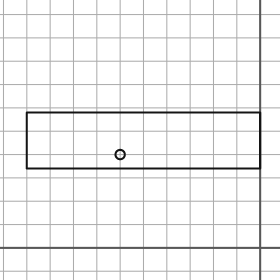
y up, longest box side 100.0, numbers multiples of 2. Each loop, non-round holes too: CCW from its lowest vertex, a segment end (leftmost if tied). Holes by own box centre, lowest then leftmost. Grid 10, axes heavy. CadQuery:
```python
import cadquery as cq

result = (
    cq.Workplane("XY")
    .moveTo(-100.0, 34.0)
    .lineTo(0.0, 34.0)
    .lineTo(0.0, 58.0)
    .lineTo(-100.0, 58.0)
    .close()
    .moveTo(-60.0, 40.0)
    .circle(2.0)
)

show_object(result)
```